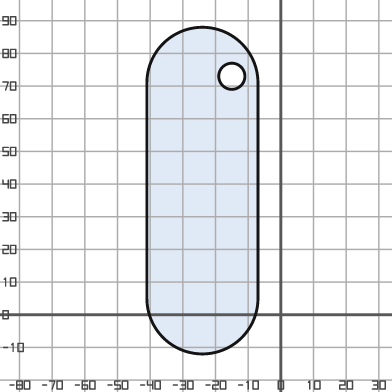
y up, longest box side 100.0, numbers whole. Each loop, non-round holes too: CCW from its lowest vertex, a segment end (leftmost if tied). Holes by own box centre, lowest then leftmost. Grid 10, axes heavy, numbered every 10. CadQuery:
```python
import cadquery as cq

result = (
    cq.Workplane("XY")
    .moveTo(-41.0, 5.0)
    .threePointArc((-24.0, -12.0), (-7.0, 5.0))
    .lineTo(-7.0, 71.0)
    .threePointArc((-24.0, 88.0), (-41.0, 71.0))
    .close()
    .moveTo(-15.0, 73.0)
    .circle(4.0)
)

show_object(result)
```